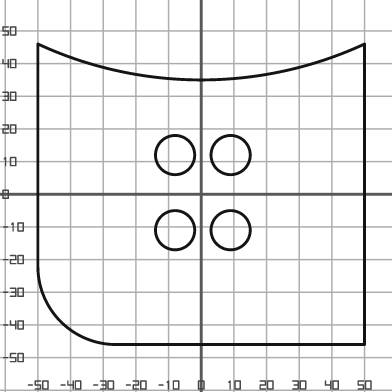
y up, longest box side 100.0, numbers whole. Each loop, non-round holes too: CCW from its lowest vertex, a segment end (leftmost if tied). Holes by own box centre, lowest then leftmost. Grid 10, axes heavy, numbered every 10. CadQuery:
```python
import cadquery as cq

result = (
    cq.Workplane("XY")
    .moveTo(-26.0, -46.0)
    .lineTo(50.0, -46.0)
    .lineTo(50.0, 46.0)
    .threePointArc((0.0, 35.0), (-50.0, 46.0))
    .lineTo(-50.0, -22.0)
    .threePointArc((-43.0, -39.0), (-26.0, -46.0))
    .close()
    .moveTo(-8.0, -11.0)
    .circle(6.0)
    .moveTo(9.0, -11.0)
    .circle(6.0)
    .moveTo(-8.0, 12.0)
    .circle(6.0)
    .moveTo(9.0, 12.0)
    .circle(6.0)
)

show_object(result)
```